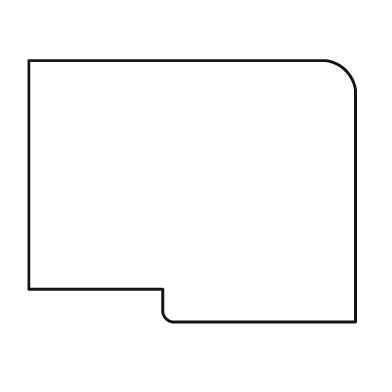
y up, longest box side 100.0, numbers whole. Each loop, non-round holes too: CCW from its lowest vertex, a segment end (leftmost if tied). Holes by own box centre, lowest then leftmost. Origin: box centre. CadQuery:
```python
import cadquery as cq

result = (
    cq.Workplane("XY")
    .moveTo(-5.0, -40.0)
    .lineTo(50.0, -40.0)
    .lineTo(50.0, 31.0)
    .threePointArc((47.0, 37.0), (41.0, 40.0))
    .lineTo(-50.0, 40.0)
    .lineTo(-50.0, -30.0)
    .lineTo(-9.0, -30.0)
    .lineTo(-9.0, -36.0)
    .threePointArc((-8.0, -39.0), (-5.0, -40.0))
    .close()
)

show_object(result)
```